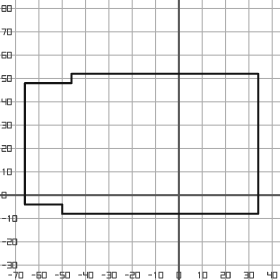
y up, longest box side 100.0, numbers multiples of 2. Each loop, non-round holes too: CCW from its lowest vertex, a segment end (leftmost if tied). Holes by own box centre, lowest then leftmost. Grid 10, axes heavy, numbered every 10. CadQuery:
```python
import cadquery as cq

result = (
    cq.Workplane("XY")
    .moveTo(-50.0, -8.0)
    .lineTo(34.0, -8.0)
    .lineTo(34.0, 52.0)
    .lineTo(-46.0, 52.0)
    .lineTo(-46.0, 48.0)
    .lineTo(-66.0, 48.0)
    .lineTo(-66.0, -4.0)
    .lineTo(-50.0, -4.0)
    .close()
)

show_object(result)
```